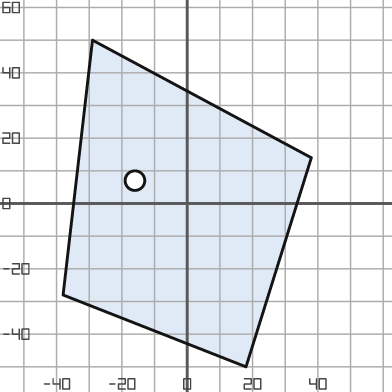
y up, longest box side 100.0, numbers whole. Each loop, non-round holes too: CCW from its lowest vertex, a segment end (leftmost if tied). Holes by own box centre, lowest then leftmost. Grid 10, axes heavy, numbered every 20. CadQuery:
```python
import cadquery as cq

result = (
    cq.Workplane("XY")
    .moveTo(18.0, -50.0)
    .lineTo(38.0, 14.0)
    .lineTo(-29.0, 50.0)
    .lineTo(-38.0, -28.0)
    .close()
    .moveTo(-16.0, 7.0)
    .circle(3.0)
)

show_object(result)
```